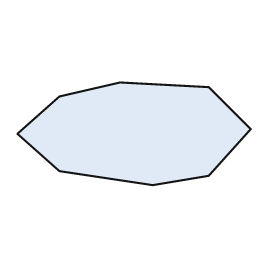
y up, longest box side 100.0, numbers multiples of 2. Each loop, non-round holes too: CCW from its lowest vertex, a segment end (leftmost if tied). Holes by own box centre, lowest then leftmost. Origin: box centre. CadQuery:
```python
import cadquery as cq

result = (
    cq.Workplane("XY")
    .moveTo(8.0, -22.0)
    .lineTo(32.0, -18.0)
    .lineTo(50.0, 2.0)
    .lineTo(32.0, 20.0)
    .lineTo(-6.0, 22.0)
    .lineTo(-32.0, 16.0)
    .lineTo(-50.0, 0.0)
    .lineTo(-32.0, -16.0)
    .close()
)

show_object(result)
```